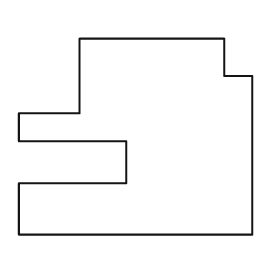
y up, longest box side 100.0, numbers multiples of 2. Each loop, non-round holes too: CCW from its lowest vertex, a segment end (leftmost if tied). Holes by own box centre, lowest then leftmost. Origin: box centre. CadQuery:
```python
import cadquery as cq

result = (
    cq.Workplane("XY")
    .moveTo(-50.0, -42.0)
    .lineTo(50.0, -42.0)
    .lineTo(50.0, 26.0)
    .lineTo(38.0, 26.0)
    .lineTo(38.0, 42.0)
    .lineTo(-24.0, 42.0)
    .lineTo(-24.0, 10.0)
    .lineTo(-50.0, 10.0)
    .lineTo(-50.0, -2.0)
    .lineTo(-4.0, -2.0)
    .lineTo(-4.0, -20.0)
    .lineTo(-50.0, -20.0)
    .close()
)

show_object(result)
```